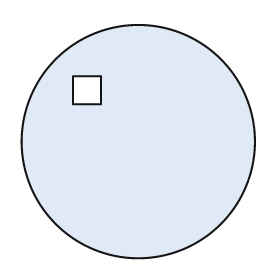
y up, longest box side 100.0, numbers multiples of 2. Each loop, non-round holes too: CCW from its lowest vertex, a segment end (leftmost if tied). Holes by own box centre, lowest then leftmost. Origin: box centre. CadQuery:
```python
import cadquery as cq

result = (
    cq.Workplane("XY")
    .moveTo(0.0, 0.0)
    .circle(50.0)
    .moveTo(-28.0, 16.0)
    .lineTo(-16.0, 16.0)
    .lineTo(-16.0, 28.0)
    .lineTo(-28.0, 28.0)
    .close()
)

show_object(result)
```